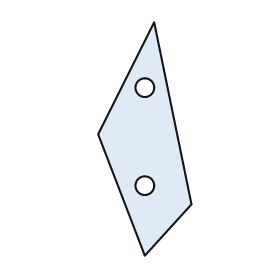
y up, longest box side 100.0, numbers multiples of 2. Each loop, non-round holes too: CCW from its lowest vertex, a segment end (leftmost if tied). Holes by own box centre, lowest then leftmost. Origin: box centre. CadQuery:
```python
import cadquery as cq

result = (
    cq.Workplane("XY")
    .moveTo(0.0, -50.0)
    .lineTo(20.0, -28.0)
    .lineTo(4.0, 50.0)
    .lineTo(-20.0, 2.0)
    .close()
    .moveTo(0.0, -20.0)
    .circle(4.0)
    .moveTo(0.0, 22.0)
    .circle(4.0)
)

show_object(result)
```